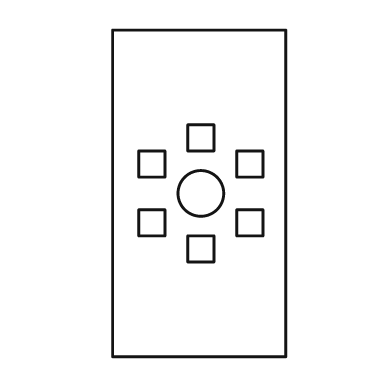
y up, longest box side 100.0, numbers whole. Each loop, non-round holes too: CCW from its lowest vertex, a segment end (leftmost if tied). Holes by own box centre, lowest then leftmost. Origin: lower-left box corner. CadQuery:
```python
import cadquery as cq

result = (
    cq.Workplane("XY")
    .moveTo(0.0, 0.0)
    .lineTo(53.0, 0.0)
    .lineTo(53.0, 100.0)
    .lineTo(0.0, 100.0)
    .close()
    .moveTo(23.0, 29.0)
    .lineTo(31.0, 29.0)
    .lineTo(31.0, 37.0)
    .lineTo(23.0, 37.0)
    .close()
    .moveTo(8.0, 37.0)
    .lineTo(16.0, 37.0)
    .lineTo(16.0, 45.0)
    .lineTo(8.0, 45.0)
    .close()
    .moveTo(38.0, 37.0)
    .lineTo(46.0, 37.0)
    .lineTo(46.0, 45.0)
    .lineTo(38.0, 45.0)
    .close()
    .moveTo(27.0, 50.0)
    .circle(7.0)
    .moveTo(8.0, 55.0)
    .lineTo(16.0, 55.0)
    .lineTo(16.0, 63.0)
    .lineTo(8.0, 63.0)
    .close()
    .moveTo(38.0, 55.0)
    .lineTo(46.0, 55.0)
    .lineTo(46.0, 63.0)
    .lineTo(38.0, 63.0)
    .close()
    .moveTo(23.0, 63.0)
    .lineTo(31.0, 63.0)
    .lineTo(31.0, 71.0)
    .lineTo(23.0, 71.0)
    .close()
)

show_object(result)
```